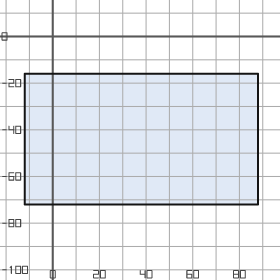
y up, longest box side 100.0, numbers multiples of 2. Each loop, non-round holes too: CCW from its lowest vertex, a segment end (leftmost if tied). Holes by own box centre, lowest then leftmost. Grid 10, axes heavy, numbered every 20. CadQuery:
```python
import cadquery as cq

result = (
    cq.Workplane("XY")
    .moveTo(-12.0, -72.0)
    .lineTo(88.0, -72.0)
    .lineTo(88.0, -16.0)
    .lineTo(-12.0, -16.0)
    .close()
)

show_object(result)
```